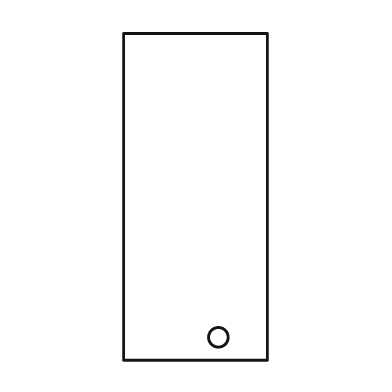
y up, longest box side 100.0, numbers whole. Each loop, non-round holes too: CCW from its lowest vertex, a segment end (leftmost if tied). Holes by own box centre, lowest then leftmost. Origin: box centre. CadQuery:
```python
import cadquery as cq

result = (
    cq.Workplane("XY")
    .moveTo(-22.0, -50.0)
    .lineTo(22.0, -50.0)
    .lineTo(22.0, 50.0)
    .lineTo(-22.0, 50.0)
    .close()
    .moveTo(7.0, -43.0)
    .circle(3.0)
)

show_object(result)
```